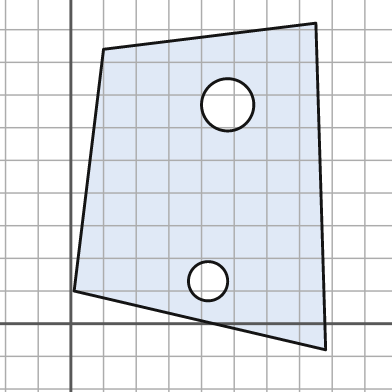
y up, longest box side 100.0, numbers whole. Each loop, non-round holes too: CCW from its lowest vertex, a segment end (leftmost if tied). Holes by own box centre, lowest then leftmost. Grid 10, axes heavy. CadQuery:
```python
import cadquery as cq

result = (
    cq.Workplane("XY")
    .moveTo(78.0, -8.0)
    .lineTo(75.0, 92.0)
    .lineTo(10.0, 84.0)
    .lineTo(1.0, 10.0)
    .close()
    .moveTo(42.0, 13.0)
    .circle(6.0)
    .moveTo(48.0, 67.0)
    .circle(8.0)
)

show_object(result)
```